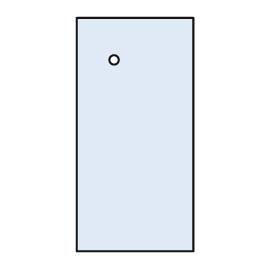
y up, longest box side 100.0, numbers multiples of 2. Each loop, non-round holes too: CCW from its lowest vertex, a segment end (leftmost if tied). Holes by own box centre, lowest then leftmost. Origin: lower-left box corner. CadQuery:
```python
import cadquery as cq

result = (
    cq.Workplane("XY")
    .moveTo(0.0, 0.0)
    .lineTo(50.0, 0.0)
    .lineTo(50.0, 100.0)
    .lineTo(0.0, 100.0)
    .close()
    .moveTo(16.0, 82.0)
    .circle(2.0)
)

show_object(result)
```